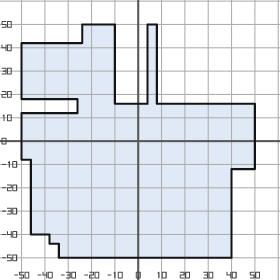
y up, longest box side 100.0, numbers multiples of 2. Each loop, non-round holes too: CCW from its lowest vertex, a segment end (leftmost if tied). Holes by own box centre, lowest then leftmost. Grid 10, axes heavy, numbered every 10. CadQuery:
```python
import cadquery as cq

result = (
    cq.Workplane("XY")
    .moveTo(-34.0, -50.0)
    .lineTo(40.0, -50.0)
    .lineTo(40.0, -12.0)
    .lineTo(50.0, -12.0)
    .lineTo(50.0, 16.0)
    .lineTo(8.0, 16.0)
    .lineTo(8.0, 50.0)
    .lineTo(4.0, 50.0)
    .lineTo(4.0, 16.0)
    .lineTo(-10.0, 16.0)
    .lineTo(-10.0, 50.0)
    .lineTo(-24.0, 50.0)
    .lineTo(-24.0, 42.0)
    .lineTo(-50.0, 42.0)
    .lineTo(-50.0, 18.0)
    .lineTo(-26.0, 18.0)
    .lineTo(-26.0, 12.0)
    .lineTo(-50.0, 12.0)
    .lineTo(-50.0, -8.0)
    .lineTo(-46.0, -8.0)
    .lineTo(-46.0, -40.0)
    .lineTo(-38.0, -40.0)
    .lineTo(-38.0, -44.0)
    .lineTo(-34.0, -44.0)
    .close()
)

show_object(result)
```